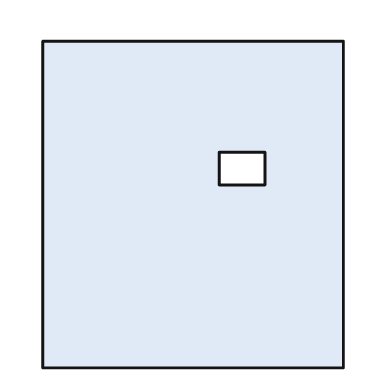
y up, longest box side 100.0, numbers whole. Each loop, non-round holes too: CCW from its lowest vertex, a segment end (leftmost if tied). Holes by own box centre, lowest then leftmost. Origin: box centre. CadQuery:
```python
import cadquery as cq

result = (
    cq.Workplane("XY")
    .moveTo(-46.0, -50.0)
    .lineTo(46.0, -50.0)
    .lineTo(46.0, 50.0)
    .lineTo(-46.0, 50.0)
    .close()
    .moveTo(8.0, 6.0)
    .lineTo(22.0, 6.0)
    .lineTo(22.0, 16.0)
    .lineTo(8.0, 16.0)
    .close()
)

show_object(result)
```